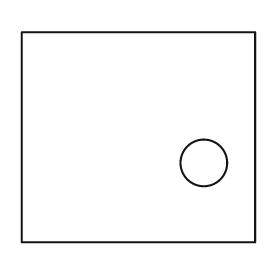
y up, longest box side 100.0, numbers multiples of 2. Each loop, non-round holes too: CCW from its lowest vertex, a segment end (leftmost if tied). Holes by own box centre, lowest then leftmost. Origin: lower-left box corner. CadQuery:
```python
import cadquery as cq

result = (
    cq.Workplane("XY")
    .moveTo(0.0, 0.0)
    .lineTo(100.0, 0.0)
    .lineTo(100.0, 90.0)
    .lineTo(0.0, 90.0)
    .close()
    .moveTo(78.0, 34.0)
    .circle(10.0)
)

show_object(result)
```